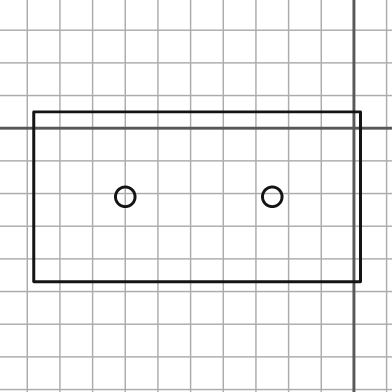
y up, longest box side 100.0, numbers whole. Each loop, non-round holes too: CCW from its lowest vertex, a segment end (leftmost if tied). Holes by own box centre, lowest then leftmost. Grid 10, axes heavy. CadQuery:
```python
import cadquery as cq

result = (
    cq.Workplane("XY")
    .moveTo(-98.0, -47.0)
    .lineTo(2.0, -47.0)
    .lineTo(2.0, 5.0)
    .lineTo(-98.0, 5.0)
    .close()
    .moveTo(-70.0, -21.0)
    .circle(3.0)
    .moveTo(-25.0, -21.0)
    .circle(3.0)
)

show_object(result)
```